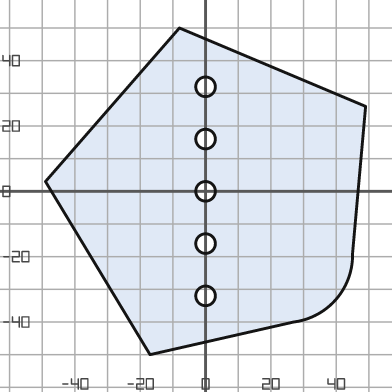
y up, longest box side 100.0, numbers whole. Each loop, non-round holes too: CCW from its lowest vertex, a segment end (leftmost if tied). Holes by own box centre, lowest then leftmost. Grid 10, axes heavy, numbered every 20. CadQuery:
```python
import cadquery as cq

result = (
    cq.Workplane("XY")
    .moveTo(-17.0, -50.0)
    .lineTo(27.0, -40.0)
    .threePointArc((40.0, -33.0), (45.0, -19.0))
    .lineTo(49.0, 26.0)
    .lineTo(-8.0, 50.0)
    .lineTo(-49.0, 3.0)
    .close()
    .moveTo(0.0, -32.0)
    .circle(3.0)
    .moveTo(0.0, -16.0)
    .circle(3.0)
    .moveTo(0.0, 0.0)
    .circle(3.0)
    .moveTo(0.0, 16.0)
    .circle(3.0)
    .moveTo(0.0, 32.0)
    .circle(3.0)
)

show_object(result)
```